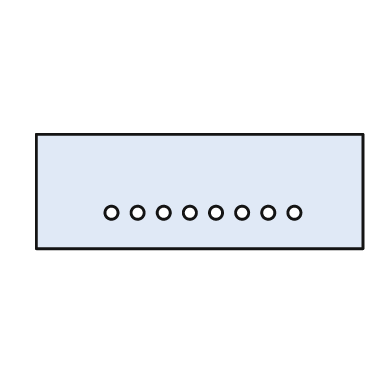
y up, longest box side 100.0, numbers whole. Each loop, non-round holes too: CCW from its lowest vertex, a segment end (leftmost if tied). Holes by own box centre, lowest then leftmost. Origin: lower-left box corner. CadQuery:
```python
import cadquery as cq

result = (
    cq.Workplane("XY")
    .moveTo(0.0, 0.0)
    .lineTo(100.0, 0.0)
    .lineTo(100.0, 35.0)
    .lineTo(0.0, 35.0)
    .close()
    .moveTo(23.0, 11.0)
    .circle(2.0)
    .moveTo(31.0, 11.0)
    .circle(2.0)
    .moveTo(39.0, 11.0)
    .circle(2.0)
    .moveTo(47.0, 11.0)
    .circle(2.0)
    .moveTo(55.0, 11.0)
    .circle(2.0)
    .moveTo(63.0, 11.0)
    .circle(2.0)
    .moveTo(71.0, 11.0)
    .circle(2.0)
    .moveTo(79.0, 11.0)
    .circle(2.0)
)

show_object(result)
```